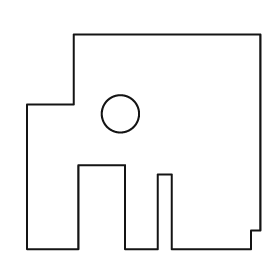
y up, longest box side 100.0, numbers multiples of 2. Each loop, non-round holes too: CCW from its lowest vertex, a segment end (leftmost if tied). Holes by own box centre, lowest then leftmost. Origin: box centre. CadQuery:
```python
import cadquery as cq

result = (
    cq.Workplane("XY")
    .moveTo(-50.0, -46.0)
    .lineTo(-28.0, -46.0)
    .lineTo(-28.0, -10.0)
    .lineTo(-8.0, -10.0)
    .lineTo(-8.0, -46.0)
    .lineTo(6.0, -46.0)
    .lineTo(6.0, -14.0)
    .lineTo(12.0, -14.0)
    .lineTo(12.0, -46.0)
    .lineTo(46.0, -46.0)
    .lineTo(46.0, -38.0)
    .lineTo(50.0, -38.0)
    .lineTo(50.0, 46.0)
    .lineTo(-30.0, 46.0)
    .lineTo(-30.0, 16.0)
    .lineTo(-50.0, 16.0)
    .close()
    .moveTo(-10.0, 12.0)
    .circle(8.0)
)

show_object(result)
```